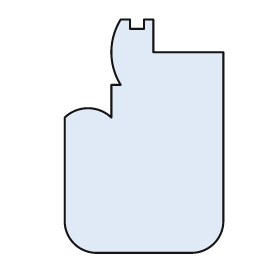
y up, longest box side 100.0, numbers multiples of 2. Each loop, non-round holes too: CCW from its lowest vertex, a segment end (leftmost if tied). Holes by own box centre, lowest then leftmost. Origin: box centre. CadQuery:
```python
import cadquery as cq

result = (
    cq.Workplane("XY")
    .moveTo(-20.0, -50.0)
    .lineTo(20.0, -50.0)
    .threePointArc((30.0, -46.0), (34.0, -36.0))
    .lineTo(34.0, 36.0)
    .lineTo(4.0, 36.0)
    .lineTo(4.0, 50.0)
    .lineTo(0.0, 50.0)
    .lineTo(0.0, 46.0)
    .lineTo(-6.0, 46.0)
    .lineTo(-6.0, 50.0)
    .lineTo(-10.0, 50.0)
    .threePointArc((-14.0, 36.0), (-10.0, 22.0))
    .lineTo(-14.0, 22.0)
    .lineTo(-14.0, 8.0)
    .threePointArc((-24.0, 12.0), (-34.0, 8.0))
    .lineTo(-34.0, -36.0)
    .threePointArc((-30.0, -46.0), (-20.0, -50.0))
    .close()
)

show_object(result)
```